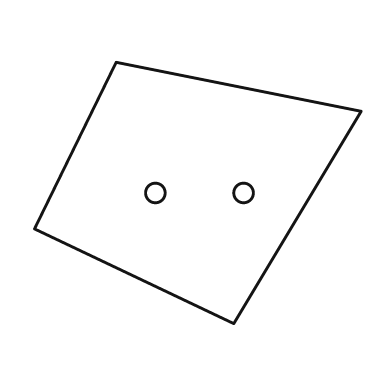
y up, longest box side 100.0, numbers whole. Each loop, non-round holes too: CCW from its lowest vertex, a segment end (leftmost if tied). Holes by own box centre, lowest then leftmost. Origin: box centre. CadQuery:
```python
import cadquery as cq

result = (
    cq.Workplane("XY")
    .moveTo(11.0, -40.0)
    .lineTo(50.0, 25.0)
    .lineTo(-25.0, 40.0)
    .lineTo(-50.0, -11.0)
    .close()
    .moveTo(-13.0, 0.0)
    .circle(3.0)
    .moveTo(14.0, 0.0)
    .circle(3.0)
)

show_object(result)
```